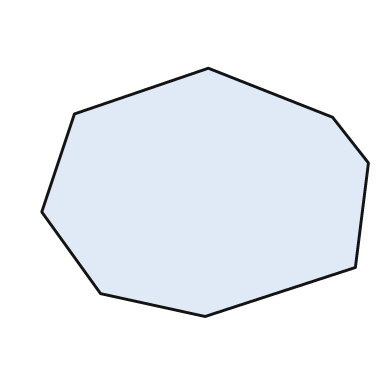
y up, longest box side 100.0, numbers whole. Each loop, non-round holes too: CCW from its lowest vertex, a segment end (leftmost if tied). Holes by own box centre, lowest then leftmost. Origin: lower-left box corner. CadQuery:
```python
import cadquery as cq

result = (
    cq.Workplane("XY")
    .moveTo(50.0, 0.0)
    .lineTo(96.0, 15.0)
    .lineTo(100.0, 47.0)
    .lineTo(89.0, 61.0)
    .lineTo(51.0, 76.0)
    .lineTo(10.0, 62.0)
    .lineTo(0.0, 32.0)
    .lineTo(18.0, 7.0)
    .close()
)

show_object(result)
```